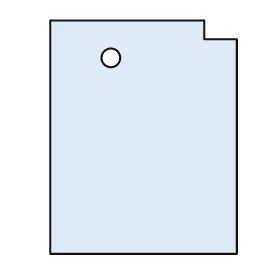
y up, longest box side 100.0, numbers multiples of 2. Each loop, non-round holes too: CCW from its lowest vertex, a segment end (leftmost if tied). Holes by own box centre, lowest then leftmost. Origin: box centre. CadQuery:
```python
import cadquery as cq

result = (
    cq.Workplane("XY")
    .moveTo(-40.0, -50.0)
    .lineTo(40.0, -50.0)
    .lineTo(40.0, 42.0)
    .lineTo(26.0, 42.0)
    .lineTo(26.0, 50.0)
    .lineTo(-40.0, 50.0)
    .close()
    .moveTo(-14.0, 34.0)
    .circle(4.0)
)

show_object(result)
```